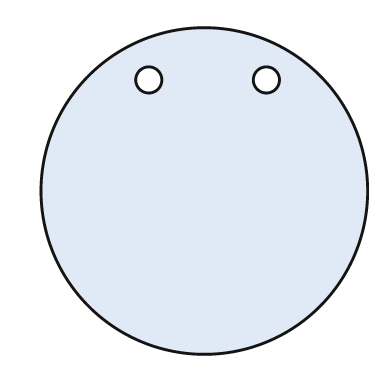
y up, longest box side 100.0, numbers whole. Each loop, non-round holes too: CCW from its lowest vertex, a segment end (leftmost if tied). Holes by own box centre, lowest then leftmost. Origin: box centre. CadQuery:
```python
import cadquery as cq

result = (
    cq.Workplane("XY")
    .moveTo(0.0, 0.0)
    .circle(50.0)
    .moveTo(-17.0, 34.0)
    .circle(4.0)
    .moveTo(19.0, 34.0)
    .circle(4.0)
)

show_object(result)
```